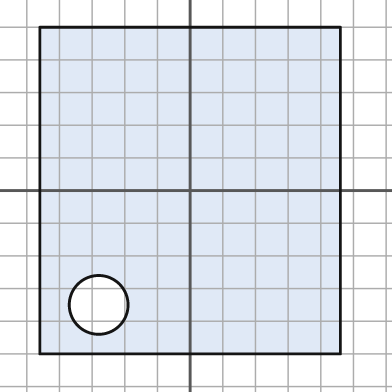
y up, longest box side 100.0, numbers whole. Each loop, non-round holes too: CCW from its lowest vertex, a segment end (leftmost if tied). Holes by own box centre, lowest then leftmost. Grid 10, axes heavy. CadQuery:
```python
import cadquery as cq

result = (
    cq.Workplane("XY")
    .moveTo(-46.0, -50.0)
    .lineTo(46.0, -50.0)
    .lineTo(46.0, 50.0)
    .lineTo(-46.0, 50.0)
    .close()
    .moveTo(-28.0, -35.0)
    .circle(9.0)
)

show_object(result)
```